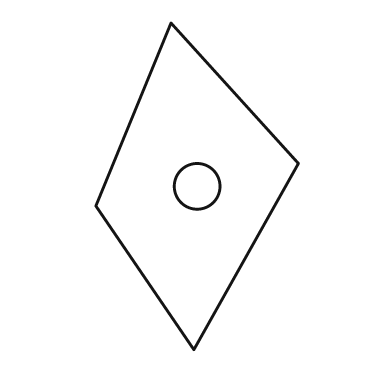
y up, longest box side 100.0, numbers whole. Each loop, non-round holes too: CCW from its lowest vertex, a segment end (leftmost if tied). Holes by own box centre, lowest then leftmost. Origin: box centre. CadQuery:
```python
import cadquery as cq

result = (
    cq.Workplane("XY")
    .moveTo(-1.0, -50.0)
    .lineTo(31.0, 7.0)
    .lineTo(-8.0, 50.0)
    .lineTo(-31.0, -6.0)
    .close()
    .moveTo(0.0, 0.0)
    .circle(7.0)
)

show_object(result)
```